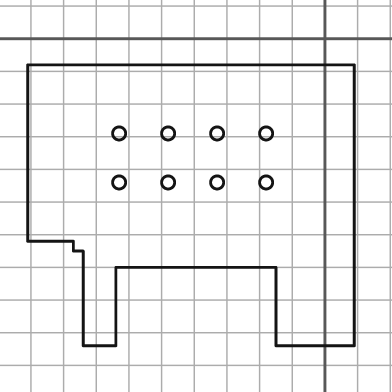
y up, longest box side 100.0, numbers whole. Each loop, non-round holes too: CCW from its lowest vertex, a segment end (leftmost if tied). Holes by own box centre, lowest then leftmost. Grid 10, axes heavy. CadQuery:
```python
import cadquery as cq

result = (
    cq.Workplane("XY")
    .moveTo(-74.0, -94.0)
    .lineTo(-64.0, -94.0)
    .lineTo(-64.0, -70.0)
    .lineTo(-15.0, -70.0)
    .lineTo(-15.0, -94.0)
    .lineTo(9.0, -94.0)
    .lineTo(9.0, -8.0)
    .lineTo(-91.0, -8.0)
    .lineTo(-91.0, -62.0)
    .lineTo(-77.0, -62.0)
    .lineTo(-77.0, -65.0)
    .lineTo(-74.0, -65.0)
    .close()
    .moveTo(-63.0, -44.0)
    .circle(2.0)
    .moveTo(-48.0, -44.0)
    .circle(2.0)
    .moveTo(-33.0, -44.0)
    .circle(2.0)
    .moveTo(-18.0, -44.0)
    .circle(2.0)
    .moveTo(-63.0, -29.0)
    .circle(2.0)
    .moveTo(-48.0, -29.0)
    .circle(2.0)
    .moveTo(-33.0, -29.0)
    .circle(2.0)
    .moveTo(-18.0, -29.0)
    .circle(2.0)
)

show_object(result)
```